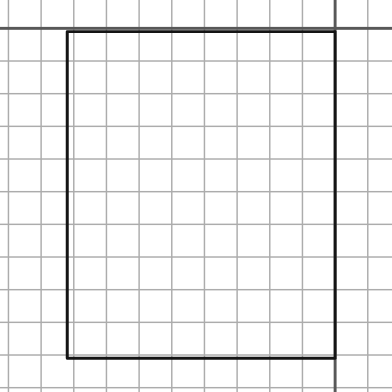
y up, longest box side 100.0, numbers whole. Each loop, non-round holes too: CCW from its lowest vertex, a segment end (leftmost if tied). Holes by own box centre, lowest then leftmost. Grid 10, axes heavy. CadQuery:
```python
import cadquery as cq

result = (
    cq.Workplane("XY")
    .moveTo(-82.0, -101.0)
    .lineTo(0.0, -101.0)
    .lineTo(0.0, -1.0)
    .lineTo(-82.0, -1.0)
    .close()
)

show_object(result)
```